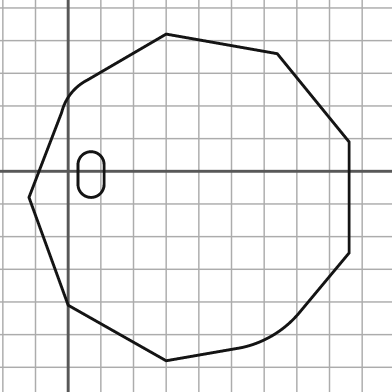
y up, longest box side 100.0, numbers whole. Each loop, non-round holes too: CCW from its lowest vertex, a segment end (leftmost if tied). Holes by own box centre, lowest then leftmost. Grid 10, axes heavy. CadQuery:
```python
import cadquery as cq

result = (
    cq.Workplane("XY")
    .moveTo(30.0, -58.0)
    .lineTo(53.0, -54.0)
    .threePointArc((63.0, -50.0), (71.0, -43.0))
    .lineTo(86.0, -25.0)
    .lineTo(86.0, 9.0)
    .lineTo(64.0, 36.0)
    .lineTo(30.0, 42.0)
    .lineTo(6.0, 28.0)
    .threePointArc((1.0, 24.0), (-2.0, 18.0))
    .lineTo(-12.0, -8.0)
    .lineTo(0.0, -41.0)
    .close()
    .moveTo(3.0, -4.0)
    .threePointArc((7.0, -8.0), (11.0, -4.0))
    .lineTo(11.0, 2.0)
    .threePointArc((7.0, 6.0), (3.0, 2.0))
    .close()
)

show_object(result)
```